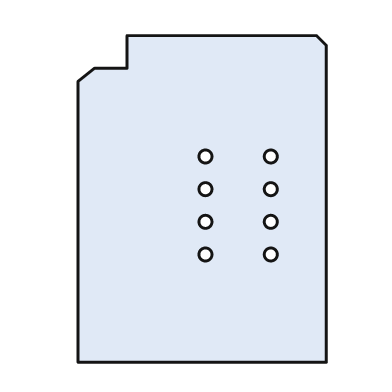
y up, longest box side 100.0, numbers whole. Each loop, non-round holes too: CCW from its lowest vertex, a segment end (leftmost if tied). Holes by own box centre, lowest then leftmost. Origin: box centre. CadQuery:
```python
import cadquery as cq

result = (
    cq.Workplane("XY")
    .moveTo(-38.0, -50.0)
    .lineTo(38.0, -50.0)
    .lineTo(38.0, 47.0)
    .lineTo(35.0, 50.0)
    .lineTo(-23.0, 50.0)
    .lineTo(-23.0, 40.0)
    .lineTo(-33.0, 40.0)
    .lineTo(-38.0, 36.0)
    .close()
    .moveTo(1.0, -17.0)
    .circle(2.0)
    .moveTo(21.0, -17.0)
    .circle(2.0)
    .moveTo(1.0, -7.0)
    .circle(2.0)
    .moveTo(21.0, -7.0)
    .circle(2.0)
    .moveTo(1.0, 3.0)
    .circle(2.0)
    .moveTo(21.0, 3.0)
    .circle(2.0)
    .moveTo(1.0, 13.0)
    .circle(2.0)
    .moveTo(21.0, 13.0)
    .circle(2.0)
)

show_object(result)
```